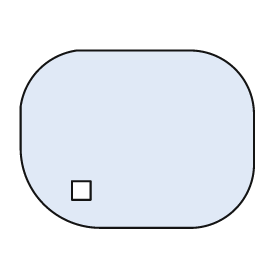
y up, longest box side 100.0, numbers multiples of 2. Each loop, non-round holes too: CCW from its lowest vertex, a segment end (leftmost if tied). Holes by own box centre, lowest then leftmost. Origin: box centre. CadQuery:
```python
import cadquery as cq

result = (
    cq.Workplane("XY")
    .moveTo(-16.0, -38.0)
    .lineTo(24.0, -38.0)
    .threePointArc((42.0, -30.0), (50.0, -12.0))
    .lineTo(50.0, 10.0)
    .threePointArc((42.0, 30.0), (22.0, 38.0))
    .lineTo(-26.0, 38.0)
    .threePointArc((-42.0, 30.0), (-50.0, 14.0))
    .lineTo(-50.0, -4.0)
    .threePointArc((-40.0, -28.0), (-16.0, -38.0))
    .close()
    .moveTo(-28.0, -26.0)
    .lineTo(-20.0, -26.0)
    .lineTo(-20.0, -18.0)
    .lineTo(-28.0, -18.0)
    .close()
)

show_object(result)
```